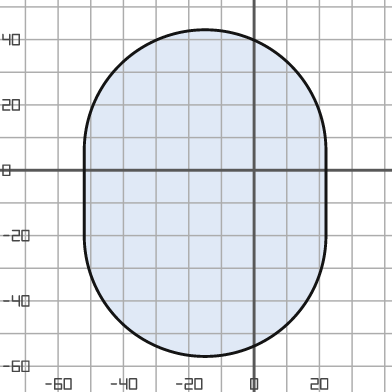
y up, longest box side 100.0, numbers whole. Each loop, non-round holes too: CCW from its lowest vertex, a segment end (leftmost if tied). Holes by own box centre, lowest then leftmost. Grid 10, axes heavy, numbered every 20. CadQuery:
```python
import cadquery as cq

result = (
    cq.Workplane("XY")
    .moveTo(-52.0, -20.0)
    .threePointArc((-15.0, -57.0), (22.0, -20.0))
    .lineTo(22.0, 6.0)
    .threePointArc((-15.0, 43.0), (-52.0, 6.0))
    .close()
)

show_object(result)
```